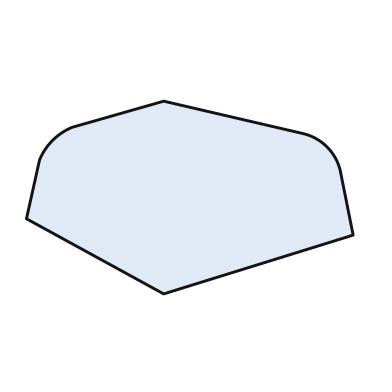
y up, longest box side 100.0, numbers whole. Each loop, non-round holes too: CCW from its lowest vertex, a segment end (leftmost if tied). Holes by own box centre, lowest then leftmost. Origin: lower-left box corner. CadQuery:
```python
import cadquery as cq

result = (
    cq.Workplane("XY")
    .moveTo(42.0, 0.0)
    .lineTo(100.0, 18.0)
    .lineTo(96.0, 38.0)
    .threePointArc((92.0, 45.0), (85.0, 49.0))
    .lineTo(42.0, 59.0)
    .lineTo(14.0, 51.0)
    .threePointArc((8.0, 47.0), (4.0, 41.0))
    .lineTo(0.0, 23.0)
    .close()
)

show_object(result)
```